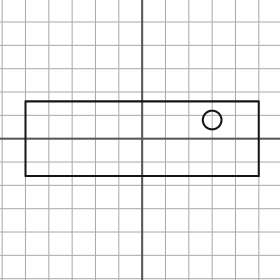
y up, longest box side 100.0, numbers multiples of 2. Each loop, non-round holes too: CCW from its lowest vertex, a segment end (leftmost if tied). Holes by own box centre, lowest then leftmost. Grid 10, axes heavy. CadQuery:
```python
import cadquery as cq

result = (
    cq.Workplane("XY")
    .moveTo(-50.0, -16.0)
    .lineTo(50.0, -16.0)
    .lineTo(50.0, 16.0)
    .lineTo(-50.0, 16.0)
    .close()
    .moveTo(30.0, 8.0)
    .circle(4.0)
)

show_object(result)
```